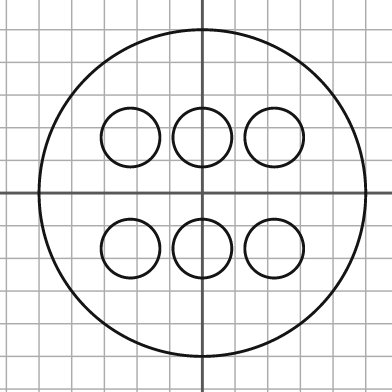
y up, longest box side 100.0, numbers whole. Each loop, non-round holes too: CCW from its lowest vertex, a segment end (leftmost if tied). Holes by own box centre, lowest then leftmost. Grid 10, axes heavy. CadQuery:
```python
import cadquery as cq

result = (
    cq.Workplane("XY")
    .moveTo(0.0, 0.0)
    .circle(50.0)
    .moveTo(-22.0, -17.0)
    .circle(9.0)
    .moveTo(0.0, -17.0)
    .circle(9.0)
    .moveTo(22.0, -17.0)
    .circle(9.0)
    .moveTo(-22.0, 17.0)
    .circle(9.0)
    .moveTo(0.0, 17.0)
    .circle(9.0)
    .moveTo(22.0, 17.0)
    .circle(9.0)
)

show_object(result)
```